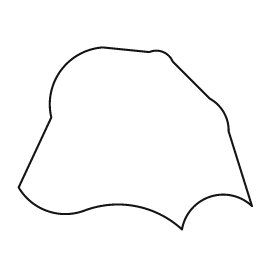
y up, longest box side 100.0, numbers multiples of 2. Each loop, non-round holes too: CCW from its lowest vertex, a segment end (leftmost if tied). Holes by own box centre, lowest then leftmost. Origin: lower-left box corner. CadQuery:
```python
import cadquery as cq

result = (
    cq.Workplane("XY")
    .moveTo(70.0, 0.0)
    .threePointArc((82.0, 14.0), (100.0, 10.0))
    .lineTo(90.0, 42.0)
    .threePointArc((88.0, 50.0), (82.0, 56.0))
    .lineTo(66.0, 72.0)
    .threePointArc((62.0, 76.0), (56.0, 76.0))
    .lineTo(36.0, 78.0)
    .threePointArc((18.0, 68.0), (14.0, 48.0))
    .lineTo(0.0, 18.0)
    .threePointArc((12.0, 8.0), (28.0, 8.0))
    .threePointArc((50.0, 10.0), (70.0, 0.0))
    .close()
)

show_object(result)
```